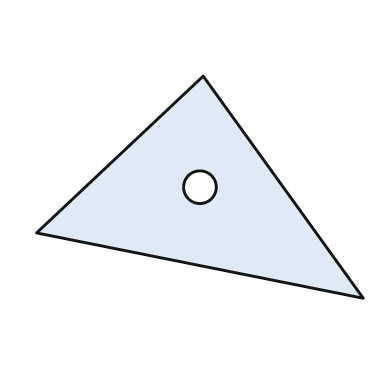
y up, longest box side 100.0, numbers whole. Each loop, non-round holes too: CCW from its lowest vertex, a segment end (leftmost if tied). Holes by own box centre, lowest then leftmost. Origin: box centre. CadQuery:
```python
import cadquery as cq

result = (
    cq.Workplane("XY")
    .moveTo(50.0, -34.0)
    .lineTo(1.0, 34.0)
    .lineTo(-50.0, -14.0)
    .close()
    .moveTo(0.0, 0.0)
    .circle(5.0)
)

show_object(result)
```